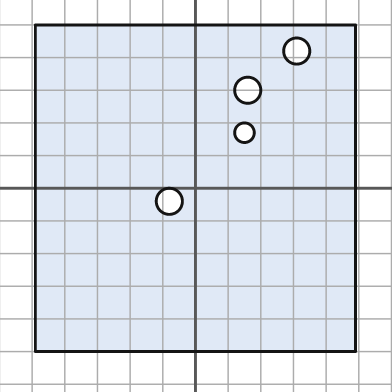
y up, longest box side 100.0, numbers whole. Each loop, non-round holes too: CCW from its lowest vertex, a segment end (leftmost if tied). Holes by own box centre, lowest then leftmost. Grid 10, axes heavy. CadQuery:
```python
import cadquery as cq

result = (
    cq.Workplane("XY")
    .moveTo(-49.0, -50.0)
    .lineTo(49.0, -50.0)
    .lineTo(49.0, 50.0)
    .lineTo(-49.0, 50.0)
    .close()
    .moveTo(-8.0, -4.0)
    .circle(4.0)
    .moveTo(15.0, 17.0)
    .circle(3.0)
    .moveTo(16.0, 30.0)
    .circle(4.0)
    .moveTo(31.0, 42.0)
    .circle(4.0)
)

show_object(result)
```